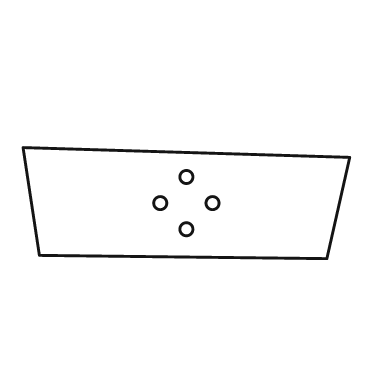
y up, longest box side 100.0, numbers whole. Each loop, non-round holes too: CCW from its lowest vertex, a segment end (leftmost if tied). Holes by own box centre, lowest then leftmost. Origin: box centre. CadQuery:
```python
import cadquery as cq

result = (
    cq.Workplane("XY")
    .moveTo(43.0, -17.0)
    .lineTo(50.0, 14.0)
    .lineTo(-50.0, 17.0)
    .lineTo(-45.0, -16.0)
    .close()
    .moveTo(0.0, -8.0)
    .circle(2.0)
    .moveTo(-8.0, 0.0)
    .circle(2.0)
    .moveTo(8.0, 0.0)
    .circle(2.0)
    .moveTo(0.0, 8.0)
    .circle(2.0)
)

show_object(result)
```